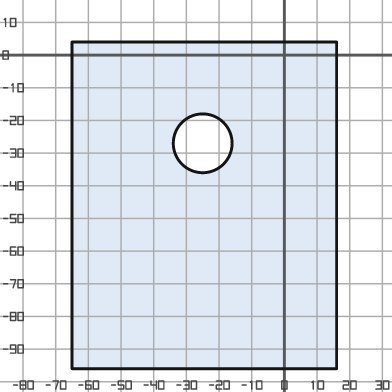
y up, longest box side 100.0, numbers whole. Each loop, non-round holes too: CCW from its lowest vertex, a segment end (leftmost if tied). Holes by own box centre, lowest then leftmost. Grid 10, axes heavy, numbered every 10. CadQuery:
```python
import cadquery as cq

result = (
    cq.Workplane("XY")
    .moveTo(-65.0, -96.0)
    .lineTo(16.0, -96.0)
    .lineTo(16.0, 4.0)
    .lineTo(-65.0, 4.0)
    .close()
    .moveTo(-25.0, -27.0)
    .circle(9.0)
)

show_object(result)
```